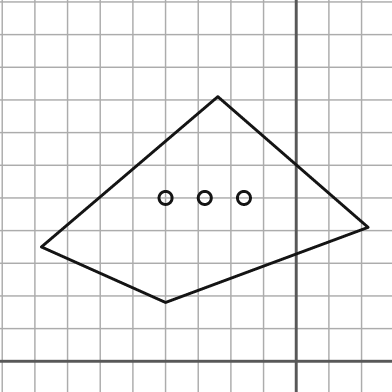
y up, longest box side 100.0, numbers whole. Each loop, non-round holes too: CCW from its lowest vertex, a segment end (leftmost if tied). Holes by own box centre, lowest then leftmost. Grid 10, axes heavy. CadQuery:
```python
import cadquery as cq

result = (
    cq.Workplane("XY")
    .moveTo(-40.0, 18.0)
    .lineTo(22.0, 41.0)
    .lineTo(-24.0, 81.0)
    .lineTo(-78.0, 35.0)
    .close()
    .moveTo(-40.0, 50.0)
    .circle(2.0)
    .moveTo(-28.0, 50.0)
    .circle(2.0)
    .moveTo(-16.0, 50.0)
    .circle(2.0)
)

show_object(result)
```